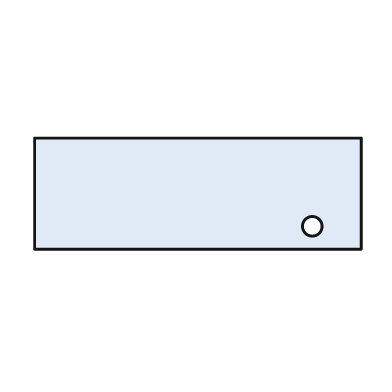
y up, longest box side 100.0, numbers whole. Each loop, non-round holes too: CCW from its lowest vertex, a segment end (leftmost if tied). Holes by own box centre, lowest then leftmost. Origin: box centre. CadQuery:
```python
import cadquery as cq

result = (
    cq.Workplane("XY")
    .moveTo(-50.0, -17.0)
    .lineTo(50.0, -17.0)
    .lineTo(50.0, 17.0)
    .lineTo(-50.0, 17.0)
    .close()
    .moveTo(35.0, -10.0)
    .circle(3.0)
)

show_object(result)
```